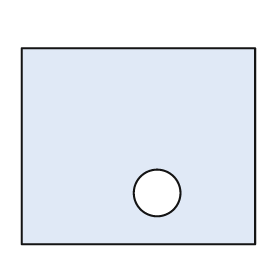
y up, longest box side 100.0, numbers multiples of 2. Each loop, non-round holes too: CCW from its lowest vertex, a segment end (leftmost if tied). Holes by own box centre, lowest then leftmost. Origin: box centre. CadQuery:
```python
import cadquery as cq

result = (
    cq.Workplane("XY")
    .moveTo(-50.0, -42.0)
    .lineTo(50.0, -42.0)
    .lineTo(50.0, 42.0)
    .lineTo(-50.0, 42.0)
    .close()
    .moveTo(8.0, -20.0)
    .circle(10.0)
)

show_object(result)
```